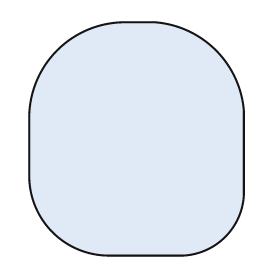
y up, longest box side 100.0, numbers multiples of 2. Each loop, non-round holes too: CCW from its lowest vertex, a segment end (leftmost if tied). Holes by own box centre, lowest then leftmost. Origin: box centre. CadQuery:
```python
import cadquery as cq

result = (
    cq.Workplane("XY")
    .moveTo(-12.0, -50.0)
    .lineTo(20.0, -50.0)
    .threePointArc((38.0, -42.0), (46.0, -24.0))
    .lineTo(46.0, 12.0)
    .threePointArc((34.0, 38.0), (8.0, 50.0))
    .lineTo(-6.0, 50.0)
    .threePointArc((-34.0, 38.0), (-46.0, 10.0))
    .lineTo(-46.0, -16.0)
    .threePointArc((-36.0, -40.0), (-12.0, -50.0))
    .close()
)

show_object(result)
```